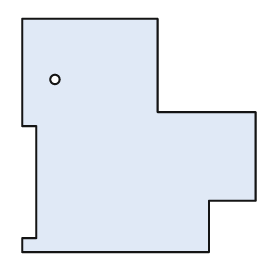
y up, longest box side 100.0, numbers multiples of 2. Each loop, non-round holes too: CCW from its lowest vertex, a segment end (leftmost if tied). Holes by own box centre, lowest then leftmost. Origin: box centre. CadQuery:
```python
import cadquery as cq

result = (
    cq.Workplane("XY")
    .moveTo(-50.0, -50.0)
    .lineTo(30.0, -50.0)
    .lineTo(30.0, -28.0)
    .lineTo(50.0, -28.0)
    .lineTo(50.0, 10.0)
    .lineTo(8.0, 10.0)
    .lineTo(8.0, 50.0)
    .lineTo(-50.0, 50.0)
    .lineTo(-50.0, 4.0)
    .lineTo(-44.0, 4.0)
    .lineTo(-44.0, -44.0)
    .lineTo(-50.0, -44.0)
    .close()
    .moveTo(-36.0, 24.0)
    .circle(2.0)
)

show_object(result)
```